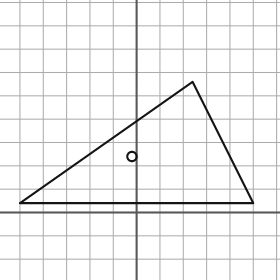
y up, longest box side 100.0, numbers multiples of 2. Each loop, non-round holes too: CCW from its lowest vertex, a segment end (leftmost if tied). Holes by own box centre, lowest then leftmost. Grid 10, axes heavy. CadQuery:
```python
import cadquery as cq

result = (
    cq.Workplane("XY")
    .moveTo(-50.0, 4.0)
    .lineTo(50.0, 4.0)
    .lineTo(24.0, 56.0)
    .close()
    .moveTo(-2.0, 24.0)
    .circle(2.0)
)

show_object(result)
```